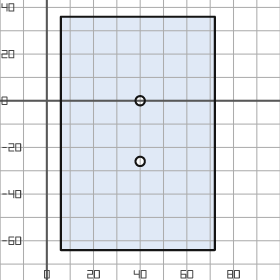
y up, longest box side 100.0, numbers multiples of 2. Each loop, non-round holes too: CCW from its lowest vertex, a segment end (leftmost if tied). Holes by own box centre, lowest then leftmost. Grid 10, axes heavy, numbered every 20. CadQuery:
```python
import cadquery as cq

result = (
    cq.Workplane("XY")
    .moveTo(6.0, -64.0)
    .lineTo(72.0, -64.0)
    .lineTo(72.0, 36.0)
    .lineTo(6.0, 36.0)
    .close()
    .moveTo(40.0, -26.0)
    .circle(2.0)
    .moveTo(40.0, 0.0)
    .circle(2.0)
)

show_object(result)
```